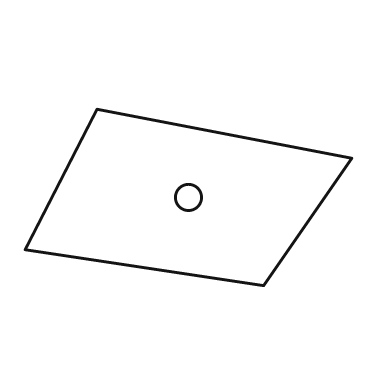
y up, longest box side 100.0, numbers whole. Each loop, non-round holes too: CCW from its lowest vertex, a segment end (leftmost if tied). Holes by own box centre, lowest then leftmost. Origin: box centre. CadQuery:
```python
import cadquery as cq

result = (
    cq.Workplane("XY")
    .moveTo(23.0, -27.0)
    .lineTo(50.0, 12.0)
    .lineTo(-28.0, 27.0)
    .lineTo(-50.0, -16.0)
    .close()
    .moveTo(0.0, 0.0)
    .circle(4.0)
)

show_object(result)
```